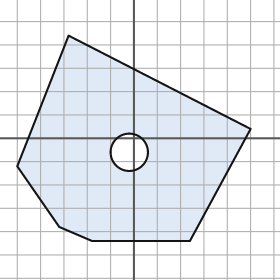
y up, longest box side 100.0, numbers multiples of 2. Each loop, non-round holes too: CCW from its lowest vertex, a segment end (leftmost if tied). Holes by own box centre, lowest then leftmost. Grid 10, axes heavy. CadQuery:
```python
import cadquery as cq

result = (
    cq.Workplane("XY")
    .moveTo(-18.0, -44.0)
    .lineTo(24.0, -44.0)
    .lineTo(50.0, 4.0)
    .lineTo(-28.0, 44.0)
    .lineTo(-50.0, -12.0)
    .lineTo(-32.0, -38.0)
    .close()
    .moveTo(-2.0, -6.0)
    .circle(8.0)
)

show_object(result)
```